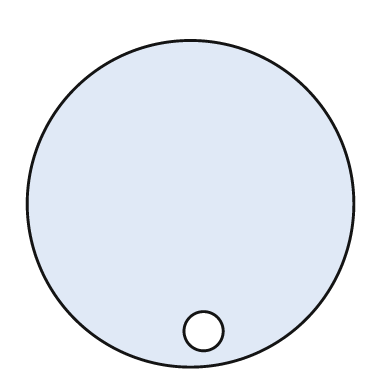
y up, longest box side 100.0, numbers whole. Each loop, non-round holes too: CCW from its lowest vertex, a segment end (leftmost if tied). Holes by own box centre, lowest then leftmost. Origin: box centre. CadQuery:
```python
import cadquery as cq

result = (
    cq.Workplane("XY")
    .moveTo(0.0, 0.0)
    .circle(50.0)
    .moveTo(4.0, -39.0)
    .circle(6.0)
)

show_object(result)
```